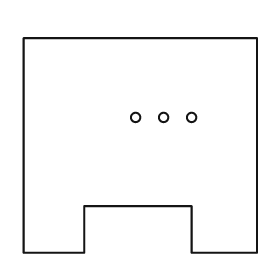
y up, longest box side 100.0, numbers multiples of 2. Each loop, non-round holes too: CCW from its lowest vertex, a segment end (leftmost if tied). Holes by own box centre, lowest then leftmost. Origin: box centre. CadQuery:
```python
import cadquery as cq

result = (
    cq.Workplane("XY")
    .moveTo(-50.0, -46.0)
    .lineTo(-24.0, -46.0)
    .lineTo(-24.0, -26.0)
    .lineTo(22.0, -26.0)
    .lineTo(22.0, -46.0)
    .lineTo(50.0, -46.0)
    .lineTo(50.0, 46.0)
    .lineTo(-50.0, 46.0)
    .close()
    .moveTo(-2.0, 12.0)
    .circle(2.0)
    .moveTo(10.0, 12.0)
    .circle(2.0)
    .moveTo(22.0, 12.0)
    .circle(2.0)
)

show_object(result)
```